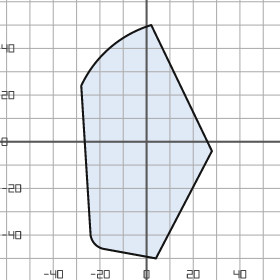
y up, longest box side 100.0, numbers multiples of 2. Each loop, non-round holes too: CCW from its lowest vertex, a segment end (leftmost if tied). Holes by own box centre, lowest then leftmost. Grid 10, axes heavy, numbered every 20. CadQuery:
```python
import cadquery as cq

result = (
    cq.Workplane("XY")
    .moveTo(4.0, -50.0)
    .lineTo(28.0, -4.0)
    .lineTo(2.0, 50.0)
    .threePointArc((-16.0, 40.0), (-28.0, 24.0))
    .lineTo(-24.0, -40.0)
    .threePointArc((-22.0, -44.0), (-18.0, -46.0))
    .close()
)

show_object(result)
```